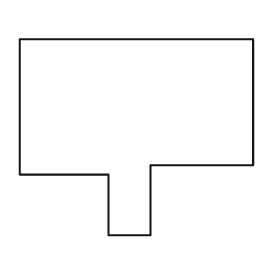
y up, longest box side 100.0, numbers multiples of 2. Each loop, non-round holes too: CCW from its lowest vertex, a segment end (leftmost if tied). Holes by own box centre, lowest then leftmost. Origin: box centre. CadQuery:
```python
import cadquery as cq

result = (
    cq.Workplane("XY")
    .moveTo(-12.0, -42.0)
    .lineTo(6.0, -42.0)
    .lineTo(6.0, -12.0)
    .lineTo(50.0, -12.0)
    .lineTo(50.0, 42.0)
    .lineTo(-50.0, 42.0)
    .lineTo(-50.0, -16.0)
    .lineTo(-12.0, -16.0)
    .close()
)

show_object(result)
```